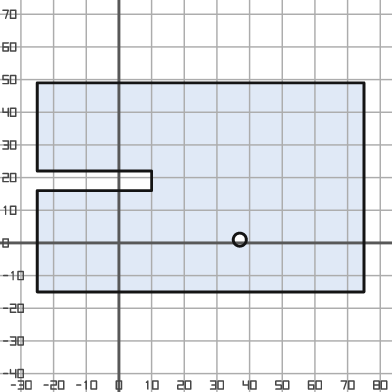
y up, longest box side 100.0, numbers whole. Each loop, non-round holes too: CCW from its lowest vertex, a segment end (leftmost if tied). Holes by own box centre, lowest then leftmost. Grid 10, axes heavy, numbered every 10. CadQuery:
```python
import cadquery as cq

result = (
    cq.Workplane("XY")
    .moveTo(-25.0, -15.0)
    .lineTo(75.0, -15.0)
    .lineTo(75.0, 49.0)
    .lineTo(-25.0, 49.0)
    .lineTo(-25.0, 22.0)
    .lineTo(10.0, 22.0)
    .lineTo(10.0, 16.0)
    .lineTo(-25.0, 16.0)
    .close()
    .moveTo(37.0, 1.0)
    .circle(2.0)
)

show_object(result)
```